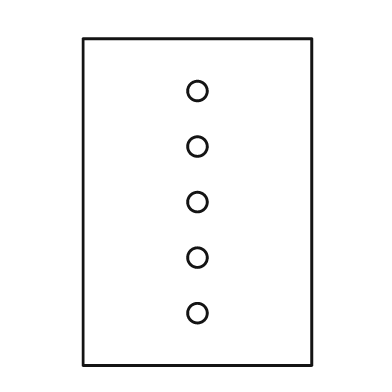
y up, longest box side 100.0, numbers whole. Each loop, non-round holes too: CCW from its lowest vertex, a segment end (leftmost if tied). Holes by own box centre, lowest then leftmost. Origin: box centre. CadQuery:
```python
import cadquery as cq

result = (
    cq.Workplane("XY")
    .moveTo(-35.0, -50.0)
    .lineTo(35.0, -50.0)
    .lineTo(35.0, 50.0)
    .lineTo(-35.0, 50.0)
    .close()
    .moveTo(0.0, -34.0)
    .circle(3.0)
    .moveTo(0.0, -17.0)
    .circle(3.0)
    .moveTo(0.0, 0.0)
    .circle(3.0)
    .moveTo(0.0, 17.0)
    .circle(3.0)
    .moveTo(0.0, 34.0)
    .circle(3.0)
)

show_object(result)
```